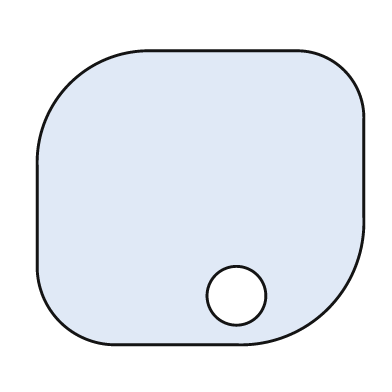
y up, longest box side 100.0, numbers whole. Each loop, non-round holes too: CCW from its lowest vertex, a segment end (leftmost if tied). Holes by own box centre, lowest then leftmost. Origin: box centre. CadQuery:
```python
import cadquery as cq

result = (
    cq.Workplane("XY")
    .moveTo(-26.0, -45.0)
    .lineTo(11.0, -45.0)
    .threePointArc((39.0, -34.0), (50.0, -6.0))
    .lineTo(50.0, 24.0)
    .threePointArc((44.0, 39.0), (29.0, 45.0))
    .lineTo(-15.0, 45.0)
    .threePointArc((-40.0, 35.0), (-50.0, 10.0))
    .lineTo(-50.0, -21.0)
    .threePointArc((-43.0, -38.0), (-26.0, -45.0))
    .close()
    .moveTo(11.0, -30.0)
    .circle(9.0)
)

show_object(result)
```